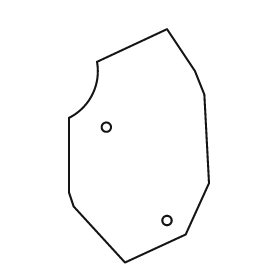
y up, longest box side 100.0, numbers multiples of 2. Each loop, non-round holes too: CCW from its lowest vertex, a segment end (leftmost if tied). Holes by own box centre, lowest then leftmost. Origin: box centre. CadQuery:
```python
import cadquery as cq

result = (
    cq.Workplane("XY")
    .moveTo(-6.0, -50.0)
    .lineTo(20.0, -38.0)
    .lineTo(30.0, -16.0)
    .lineTo(28.0, 22.0)
    .lineTo(24.0, 32.0)
    .lineTo(12.0, 50.0)
    .lineTo(-18.0, 36.0)
    .threePointArc((-20.0, 22.0), (-30.0, 12.0))
    .lineTo(-30.0, -20.0)
    .lineTo(-28.0, -26.0)
    .close()
    .moveTo(12.0, -32.0)
    .circle(2.0)
    .moveTo(-14.0, 8.0)
    .circle(2.0)
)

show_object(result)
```